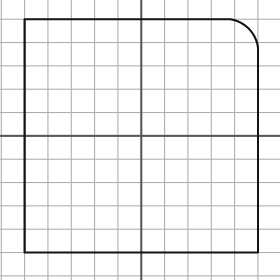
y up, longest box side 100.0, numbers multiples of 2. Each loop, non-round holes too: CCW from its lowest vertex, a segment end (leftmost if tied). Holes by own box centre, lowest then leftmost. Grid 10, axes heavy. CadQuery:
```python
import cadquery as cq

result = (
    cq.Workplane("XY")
    .moveTo(-50.0, -50.0)
    .lineTo(50.0, -50.0)
    .lineTo(50.0, 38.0)
    .threePointArc((46.0, 46.0), (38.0, 50.0))
    .lineTo(-50.0, 50.0)
    .close()
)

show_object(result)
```